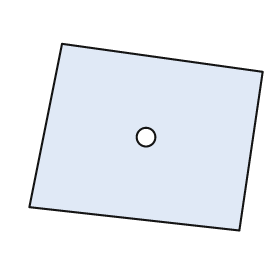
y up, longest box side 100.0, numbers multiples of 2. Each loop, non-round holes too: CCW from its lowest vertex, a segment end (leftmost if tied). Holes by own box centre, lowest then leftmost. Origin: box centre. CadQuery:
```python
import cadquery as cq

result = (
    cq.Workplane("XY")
    .moveTo(40.0, -40.0)
    .lineTo(50.0, 28.0)
    .lineTo(-36.0, 40.0)
    .lineTo(-50.0, -30.0)
    .close()
    .moveTo(0.0, 0.0)
    .circle(4.0)
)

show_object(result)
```